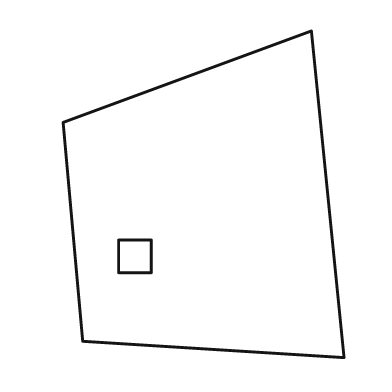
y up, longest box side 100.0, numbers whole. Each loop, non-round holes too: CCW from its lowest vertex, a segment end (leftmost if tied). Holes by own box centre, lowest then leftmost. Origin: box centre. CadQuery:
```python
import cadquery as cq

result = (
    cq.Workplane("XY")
    .moveTo(43.0, -50.0)
    .lineTo(33.0, 50.0)
    .lineTo(-43.0, 22.0)
    .lineTo(-37.0, -45.0)
    .close()
    .moveTo(-26.0, -24.0)
    .lineTo(-16.0, -24.0)
    .lineTo(-16.0, -14.0)
    .lineTo(-26.0, -14.0)
    .close()
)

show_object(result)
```